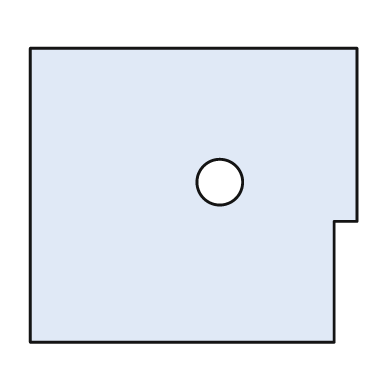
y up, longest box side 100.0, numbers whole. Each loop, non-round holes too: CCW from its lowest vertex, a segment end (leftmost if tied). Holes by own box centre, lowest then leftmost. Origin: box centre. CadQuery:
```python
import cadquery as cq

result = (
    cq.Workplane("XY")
    .moveTo(-50.0, -45.0)
    .lineTo(43.0, -45.0)
    .lineTo(43.0, -8.0)
    .lineTo(50.0, -8.0)
    .lineTo(50.0, 45.0)
    .lineTo(-50.0, 45.0)
    .close()
    .moveTo(8.0, 4.0)
    .circle(7.0)
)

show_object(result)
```